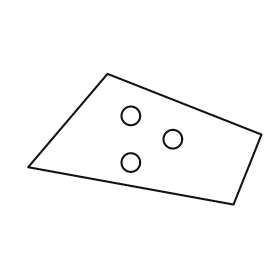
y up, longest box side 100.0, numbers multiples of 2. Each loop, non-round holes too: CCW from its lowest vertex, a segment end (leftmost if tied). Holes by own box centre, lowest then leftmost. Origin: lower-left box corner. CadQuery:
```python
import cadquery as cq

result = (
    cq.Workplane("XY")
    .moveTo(88.0, 0.0)
    .lineTo(100.0, 30.0)
    .lineTo(34.0, 56.0)
    .lineTo(0.0, 16.0)
    .close()
    .moveTo(44.0, 18.0)
    .circle(4.0)
    .moveTo(62.0, 28.0)
    .circle(4.0)
    .moveTo(44.0, 38.0)
    .circle(4.0)
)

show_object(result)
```